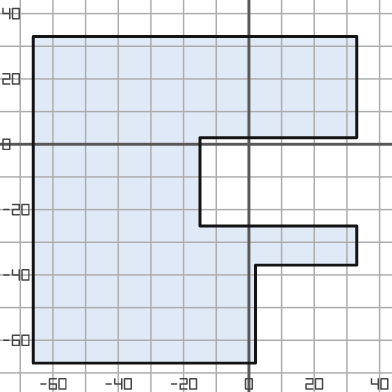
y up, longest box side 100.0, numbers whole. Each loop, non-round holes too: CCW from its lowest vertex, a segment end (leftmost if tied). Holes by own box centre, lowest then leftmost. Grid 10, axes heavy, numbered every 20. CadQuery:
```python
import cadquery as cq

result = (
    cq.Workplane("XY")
    .moveTo(-66.0, -67.0)
    .lineTo(2.0, -67.0)
    .lineTo(2.0, -37.0)
    .lineTo(33.0, -37.0)
    .lineTo(33.0, -25.0)
    .lineTo(-15.0, -25.0)
    .lineTo(-15.0, 2.0)
    .lineTo(33.0, 2.0)
    .lineTo(33.0, 33.0)
    .lineTo(-66.0, 33.0)
    .close()
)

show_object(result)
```